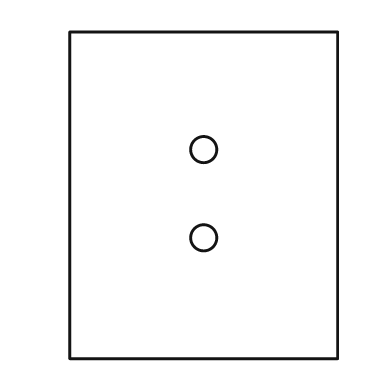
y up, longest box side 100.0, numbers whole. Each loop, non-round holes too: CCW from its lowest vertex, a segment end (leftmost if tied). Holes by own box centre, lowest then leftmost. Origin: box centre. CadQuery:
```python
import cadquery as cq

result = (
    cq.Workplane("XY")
    .moveTo(-41.0, -50.0)
    .lineTo(41.0, -50.0)
    .lineTo(41.0, 50.0)
    .lineTo(-41.0, 50.0)
    .close()
    .moveTo(0.0, -13.0)
    .circle(4.0)
    .moveTo(0.0, 14.0)
    .circle(4.0)
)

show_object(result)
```